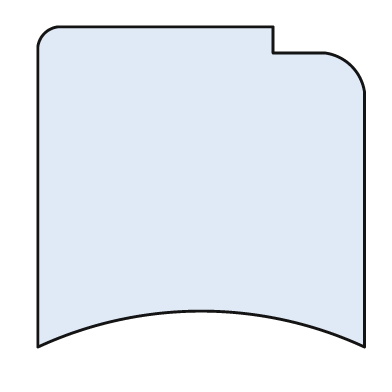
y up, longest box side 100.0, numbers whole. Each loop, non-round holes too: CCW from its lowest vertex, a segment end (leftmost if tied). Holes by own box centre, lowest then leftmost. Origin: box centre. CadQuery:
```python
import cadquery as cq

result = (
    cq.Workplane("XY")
    .moveTo(-50.0, -49.0)
    .threePointArc((0.0, -38.0), (50.0, -49.0))
    .lineTo(50.0, 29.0)
    .threePointArc((46.0, 37.0), (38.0, 41.0))
    .lineTo(22.0, 41.0)
    .lineTo(22.0, 49.0)
    .lineTo(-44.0, 49.0)
    .threePointArc((-48.0, 47.0), (-50.0, 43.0))
    .close()
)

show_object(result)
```